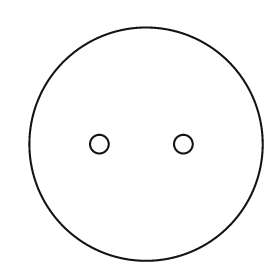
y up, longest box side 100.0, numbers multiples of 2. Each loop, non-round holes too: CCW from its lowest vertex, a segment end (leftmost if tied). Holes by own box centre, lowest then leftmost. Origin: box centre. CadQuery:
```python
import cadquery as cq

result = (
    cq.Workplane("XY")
    .moveTo(0.0, 0.0)
    .circle(50.0)
    .moveTo(-20.0, 0.0)
    .circle(4.0)
    .moveTo(16.0, 0.0)
    .circle(4.0)
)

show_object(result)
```